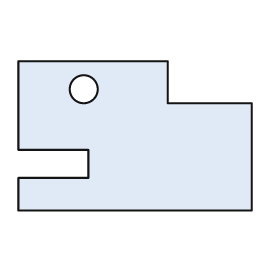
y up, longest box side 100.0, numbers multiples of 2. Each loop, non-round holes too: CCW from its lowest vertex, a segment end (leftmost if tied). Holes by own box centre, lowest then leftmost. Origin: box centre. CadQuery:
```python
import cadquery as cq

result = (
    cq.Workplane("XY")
    .moveTo(-50.0, -32.0)
    .lineTo(50.0, -32.0)
    .lineTo(50.0, 14.0)
    .lineTo(14.0, 14.0)
    .lineTo(14.0, 32.0)
    .lineTo(-50.0, 32.0)
    .lineTo(-50.0, -6.0)
    .lineTo(-20.0, -6.0)
    .lineTo(-20.0, -18.0)
    .lineTo(-50.0, -18.0)
    .close()
    .moveTo(-22.0, 20.0)
    .circle(6.0)
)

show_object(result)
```